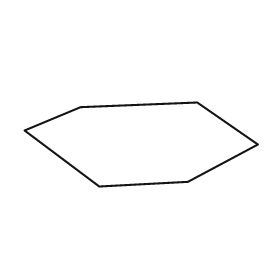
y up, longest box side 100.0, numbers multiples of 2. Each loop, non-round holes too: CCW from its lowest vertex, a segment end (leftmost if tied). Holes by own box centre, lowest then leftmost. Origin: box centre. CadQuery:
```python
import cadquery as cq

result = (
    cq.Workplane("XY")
    .moveTo(-18.0, -18.0)
    .lineTo(20.0, -16.0)
    .lineTo(50.0, 0.0)
    .lineTo(24.0, 18.0)
    .lineTo(-26.0, 16.0)
    .lineTo(-50.0, 6.0)
    .close()
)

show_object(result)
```